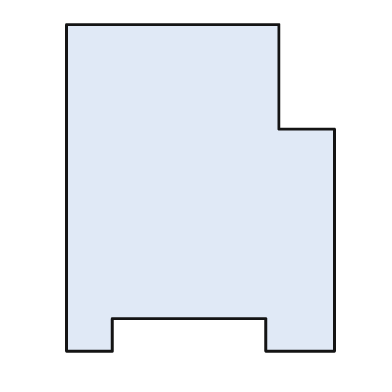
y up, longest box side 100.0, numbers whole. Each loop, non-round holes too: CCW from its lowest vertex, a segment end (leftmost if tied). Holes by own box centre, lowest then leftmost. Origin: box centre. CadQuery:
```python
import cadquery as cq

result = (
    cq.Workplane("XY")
    .moveTo(-41.0, -50.0)
    .lineTo(-27.0, -50.0)
    .lineTo(-27.0, -40.0)
    .lineTo(20.0, -40.0)
    .lineTo(20.0, -50.0)
    .lineTo(41.0, -50.0)
    .lineTo(41.0, 18.0)
    .lineTo(24.0, 18.0)
    .lineTo(24.0, 50.0)
    .lineTo(-41.0, 50.0)
    .close()
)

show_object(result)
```